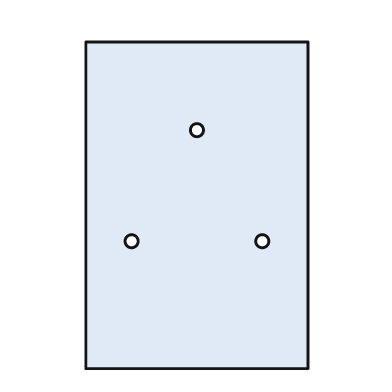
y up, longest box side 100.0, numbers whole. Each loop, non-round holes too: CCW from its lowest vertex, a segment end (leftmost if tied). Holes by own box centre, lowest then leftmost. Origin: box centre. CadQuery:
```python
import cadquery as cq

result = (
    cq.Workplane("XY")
    .moveTo(-34.0, -50.0)
    .lineTo(34.0, -50.0)
    .lineTo(34.0, 50.0)
    .lineTo(-34.0, 50.0)
    .close()
    .moveTo(-20.0, -11.0)
    .circle(2.0)
    .moveTo(20.0, -11.0)
    .circle(2.0)
    .moveTo(0.0, 23.0)
    .circle(2.0)
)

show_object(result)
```